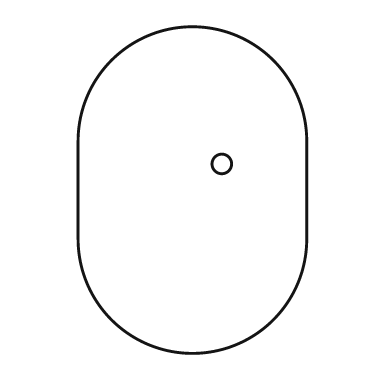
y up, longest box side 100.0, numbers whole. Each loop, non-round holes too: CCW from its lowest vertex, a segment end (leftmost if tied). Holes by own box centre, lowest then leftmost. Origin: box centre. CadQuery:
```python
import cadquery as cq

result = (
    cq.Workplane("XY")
    .moveTo(-35.0, -15.0)
    .threePointArc((0.0, -50.0), (35.0, -15.0))
    .lineTo(35.0, 15.0)
    .threePointArc((0.0, 50.0), (-35.0, 15.0))
    .close()
    .moveTo(9.0, 8.0)
    .circle(3.0)
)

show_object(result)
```